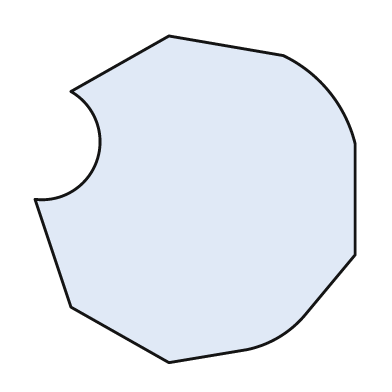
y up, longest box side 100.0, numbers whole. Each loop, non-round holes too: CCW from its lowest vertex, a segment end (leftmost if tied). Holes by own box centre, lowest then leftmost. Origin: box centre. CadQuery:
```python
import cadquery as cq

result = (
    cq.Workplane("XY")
    .moveTo(-8.0, -50.0)
    .lineTo(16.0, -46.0)
    .threePointArc((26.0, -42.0), (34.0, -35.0))
    .lineTo(49.0, -17.0)
    .lineTo(49.0, 17.0)
    .threePointArc((41.0, 33.0), (27.0, 44.0))
    .lineTo(-8.0, 50.0)
    .lineTo(-38.0, 33.0)
    .threePointArc((-30.0, 12.0), (-49.0, 0.0))
    .lineTo(-38.0, -33.0)
    .close()
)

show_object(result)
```